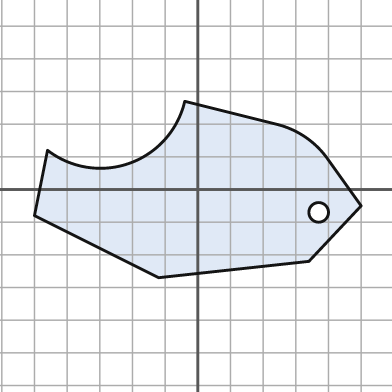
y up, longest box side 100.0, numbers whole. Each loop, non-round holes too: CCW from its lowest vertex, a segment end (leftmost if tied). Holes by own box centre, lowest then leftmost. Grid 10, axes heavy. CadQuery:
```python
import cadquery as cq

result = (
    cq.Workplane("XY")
    .moveTo(-12.0, -27.0)
    .lineTo(34.0, -22.0)
    .lineTo(50.0, -5.0)
    .lineTo(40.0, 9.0)
    .threePointArc((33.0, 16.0), (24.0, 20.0))
    .lineTo(-4.0, 27.0)
    .threePointArc((-21.0, 8.0), (-46.0, 12.0))
    .lineTo(-50.0, -8.0)
    .close()
    .moveTo(37.0, -7.0)
    .circle(3.0)
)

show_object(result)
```